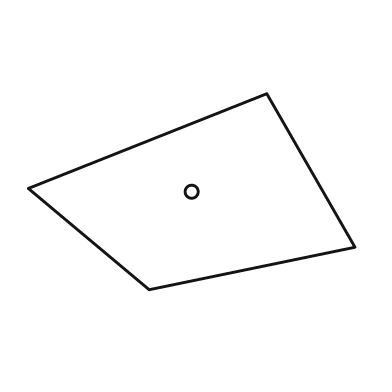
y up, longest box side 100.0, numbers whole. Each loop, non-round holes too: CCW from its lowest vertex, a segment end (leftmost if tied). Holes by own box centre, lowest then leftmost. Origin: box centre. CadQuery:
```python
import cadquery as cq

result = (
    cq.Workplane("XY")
    .moveTo(-13.0, -30.0)
    .lineTo(50.0, -17.0)
    .lineTo(23.0, 30.0)
    .lineTo(-50.0, 1.0)
    .close()
    .moveTo(0.0, 0.0)
    .circle(2.0)
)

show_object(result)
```